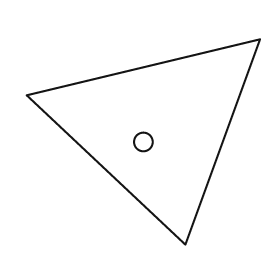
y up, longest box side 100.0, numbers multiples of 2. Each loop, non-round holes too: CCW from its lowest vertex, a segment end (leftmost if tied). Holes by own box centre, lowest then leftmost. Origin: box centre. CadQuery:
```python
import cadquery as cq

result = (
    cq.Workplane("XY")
    .moveTo(18.0, -44.0)
    .lineTo(50.0, 44.0)
    .lineTo(-50.0, 20.0)
    .close()
    .moveTo(0.0, 0.0)
    .circle(4.0)
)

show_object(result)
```